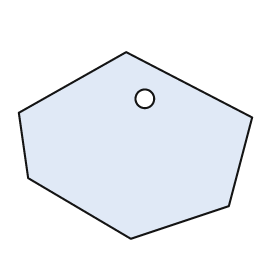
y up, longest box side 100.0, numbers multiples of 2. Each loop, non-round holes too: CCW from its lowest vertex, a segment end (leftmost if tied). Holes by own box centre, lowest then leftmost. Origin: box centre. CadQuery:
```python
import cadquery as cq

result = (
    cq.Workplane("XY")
    .moveTo(-2.0, -40.0)
    .lineTo(40.0, -26.0)
    .lineTo(50.0, 12.0)
    .lineTo(-4.0, 40.0)
    .lineTo(-50.0, 14.0)
    .lineTo(-46.0, -14.0)
    .close()
    .moveTo(4.0, 20.0)
    .circle(4.0)
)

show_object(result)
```